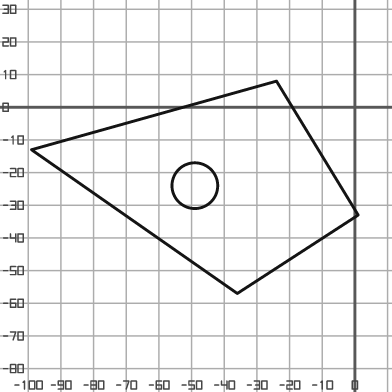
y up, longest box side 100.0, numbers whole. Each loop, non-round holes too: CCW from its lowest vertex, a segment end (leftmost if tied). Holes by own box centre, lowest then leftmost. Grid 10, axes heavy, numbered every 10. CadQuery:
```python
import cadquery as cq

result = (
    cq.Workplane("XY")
    .moveTo(-36.0, -57.0)
    .lineTo(1.0, -33.0)
    .lineTo(-24.0, 8.0)
    .lineTo(-99.0, -13.0)
    .close()
    .moveTo(-49.0, -24.0)
    .circle(7.0)
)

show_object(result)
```